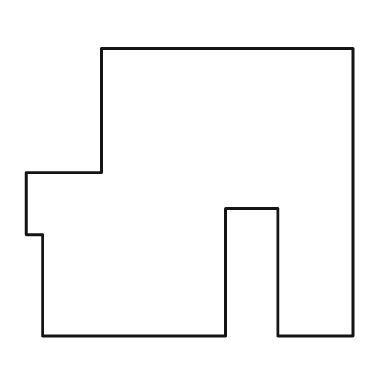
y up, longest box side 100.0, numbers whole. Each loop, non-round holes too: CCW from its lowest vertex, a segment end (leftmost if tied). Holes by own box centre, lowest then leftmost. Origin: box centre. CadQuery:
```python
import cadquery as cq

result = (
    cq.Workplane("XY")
    .moveTo(-45.0, -44.0)
    .lineTo(11.0, -44.0)
    .lineTo(11.0, -5.0)
    .lineTo(27.0, -5.0)
    .lineTo(27.0, -44.0)
    .lineTo(50.0, -44.0)
    .lineTo(50.0, 44.0)
    .lineTo(-27.0, 44.0)
    .lineTo(-27.0, 6.0)
    .lineTo(-50.0, 6.0)
    .lineTo(-50.0, -13.0)
    .lineTo(-45.0, -13.0)
    .close()
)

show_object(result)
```